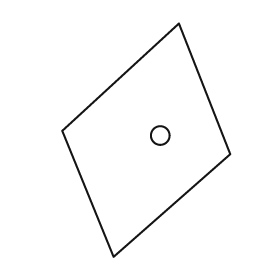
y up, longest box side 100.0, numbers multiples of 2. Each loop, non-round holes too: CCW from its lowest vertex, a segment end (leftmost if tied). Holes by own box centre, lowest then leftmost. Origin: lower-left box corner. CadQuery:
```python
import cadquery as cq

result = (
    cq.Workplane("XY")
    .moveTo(22.0, 0.0)
    .lineTo(72.0, 44.0)
    .lineTo(50.0, 100.0)
    .lineTo(0.0, 54.0)
    .close()
    .moveTo(42.0, 52.0)
    .circle(4.0)
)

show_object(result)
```